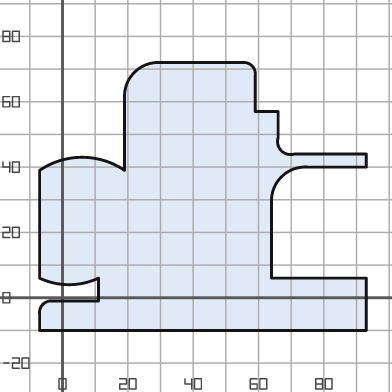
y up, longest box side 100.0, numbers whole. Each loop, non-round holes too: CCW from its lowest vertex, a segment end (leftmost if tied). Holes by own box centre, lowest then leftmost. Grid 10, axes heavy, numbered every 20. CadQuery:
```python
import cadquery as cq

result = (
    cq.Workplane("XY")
    .moveTo(-7.0, -10.0)
    .lineTo(93.0, -10.0)
    .lineTo(93.0, 6.0)
    .lineTo(64.0, 6.0)
    .lineTo(64.0, 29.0)
    .threePointArc((67.0, 37.0), (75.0, 40.0))
    .lineTo(93.0, 40.0)
    .lineTo(93.0, 44.0)
    .lineTo(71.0, 44.0)
    .threePointArc((67.0, 45.0), (66.0, 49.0))
    .lineTo(66.0, 57.0)
    .lineTo(59.0, 57.0)
    .lineTo(59.0, 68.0)
    .threePointArc((58.0, 71.0), (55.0, 72.0))
    .lineTo(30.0, 72.0)
    .threePointArc((22.0, 69.0), (19.0, 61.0))
    .lineTo(19.0, 39.0)
    .threePointArc((6.0, 43.0), (-7.0, 39.0))
    .lineTo(-7.0, 6.0)
    .threePointArc((2.0, 4.0), (11.0, 6.0))
    .lineTo(11.0, -1.0)
    .lineTo(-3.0, -1.0)
    .threePointArc((-6.0, -2.0), (-7.0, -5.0))
    .close()
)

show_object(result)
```